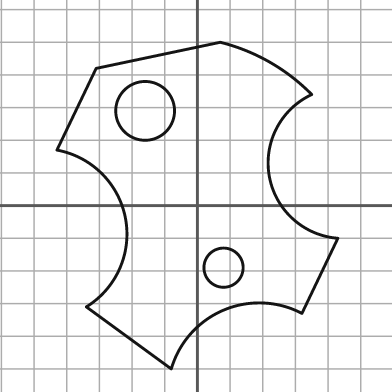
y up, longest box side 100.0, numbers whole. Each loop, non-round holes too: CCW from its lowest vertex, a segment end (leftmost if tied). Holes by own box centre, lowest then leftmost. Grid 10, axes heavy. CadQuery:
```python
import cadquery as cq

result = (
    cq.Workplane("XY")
    .moveTo(-8.0, -50.0)
    .threePointArc((8.0, -32.0), (32.0, -33.0))
    .lineTo(43.0, -10.0)
    .threePointArc((22.0, 9.0), (35.0, 34.0))
    .threePointArc((22.0, 44.0), (7.0, 50.0))
    .lineTo(-31.0, 42.0)
    .lineTo(-43.0, 17.0)
    .threePointArc((-22.0, -4.0), (-34.0, -31.0))
    .close()
    .moveTo(8.0, -19.0)
    .circle(6.0)
    .moveTo(-16.0, 29.0)
    .circle(9.0)
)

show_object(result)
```